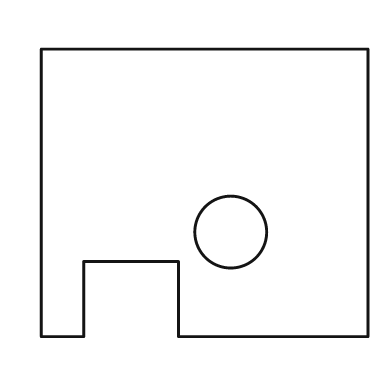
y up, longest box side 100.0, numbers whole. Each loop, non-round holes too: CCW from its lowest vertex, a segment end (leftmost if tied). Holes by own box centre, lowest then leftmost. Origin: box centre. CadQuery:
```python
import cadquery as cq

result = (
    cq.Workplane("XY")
    .moveTo(-50.0, -44.0)
    .lineTo(-37.0, -44.0)
    .lineTo(-37.0, -21.0)
    .lineTo(-8.0, -21.0)
    .lineTo(-8.0, -44.0)
    .lineTo(50.0, -44.0)
    .lineTo(50.0, 44.0)
    .lineTo(-50.0, 44.0)
    .close()
    .moveTo(8.0, -12.0)
    .circle(11.0)
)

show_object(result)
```